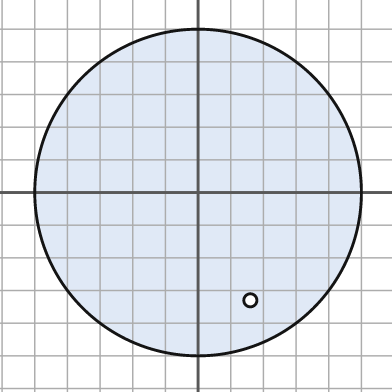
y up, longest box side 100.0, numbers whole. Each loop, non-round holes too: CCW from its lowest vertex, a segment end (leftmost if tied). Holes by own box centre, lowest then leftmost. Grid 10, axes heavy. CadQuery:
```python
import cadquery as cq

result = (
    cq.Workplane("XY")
    .moveTo(0.0, 0.0)
    .circle(50.0)
    .moveTo(16.0, -33.0)
    .circle(2.0)
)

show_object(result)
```